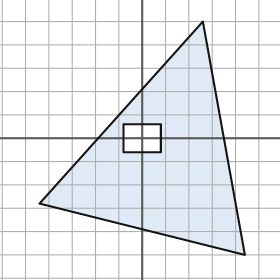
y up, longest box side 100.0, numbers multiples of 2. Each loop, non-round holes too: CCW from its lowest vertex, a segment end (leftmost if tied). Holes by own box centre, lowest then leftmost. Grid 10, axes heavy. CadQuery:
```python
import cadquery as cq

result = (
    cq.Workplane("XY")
    .moveTo(44.0, -50.0)
    .lineTo(26.0, 50.0)
    .lineTo(-44.0, -28.0)
    .close()
    .moveTo(-8.0, -6.0)
    .lineTo(8.0, -6.0)
    .lineTo(8.0, 6.0)
    .lineTo(-8.0, 6.0)
    .close()
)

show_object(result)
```